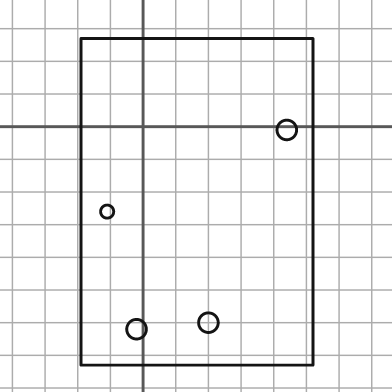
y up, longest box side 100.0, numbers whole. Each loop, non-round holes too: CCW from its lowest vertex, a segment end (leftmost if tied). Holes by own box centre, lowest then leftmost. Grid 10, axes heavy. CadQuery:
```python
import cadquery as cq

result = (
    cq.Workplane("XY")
    .moveTo(-19.0, -73.0)
    .lineTo(52.0, -73.0)
    .lineTo(52.0, 27.0)
    .lineTo(-19.0, 27.0)
    .close()
    .moveTo(-2.0, -62.0)
    .circle(3.0)
    .moveTo(20.0, -60.0)
    .circle(3.0)
    .moveTo(-11.0, -26.0)
    .circle(2.0)
    .moveTo(44.0, -1.0)
    .circle(3.0)
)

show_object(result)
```